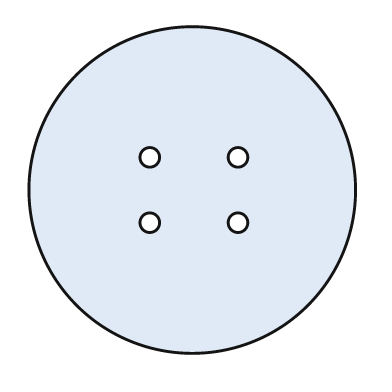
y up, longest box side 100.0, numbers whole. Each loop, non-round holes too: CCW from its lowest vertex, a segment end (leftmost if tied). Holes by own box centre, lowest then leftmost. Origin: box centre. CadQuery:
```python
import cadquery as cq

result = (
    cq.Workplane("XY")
    .moveTo(0.0, 0.0)
    .circle(50.0)
    .moveTo(-13.0, -10.0)
    .circle(3.0)
    .moveTo(14.0, -10.0)
    .circle(3.0)
    .moveTo(-13.0, 10.0)
    .circle(3.0)
    .moveTo(14.0, 10.0)
    .circle(3.0)
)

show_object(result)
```